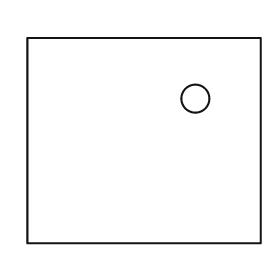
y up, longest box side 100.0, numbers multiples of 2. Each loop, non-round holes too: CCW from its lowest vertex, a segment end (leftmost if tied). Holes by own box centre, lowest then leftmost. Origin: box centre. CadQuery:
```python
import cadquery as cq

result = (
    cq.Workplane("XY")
    .moveTo(-50.0, -44.0)
    .lineTo(50.0, -44.0)
    .lineTo(50.0, 44.0)
    .lineTo(-50.0, 44.0)
    .close()
    .moveTo(22.0, 18.0)
    .circle(6.0)
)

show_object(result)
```